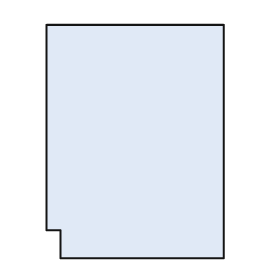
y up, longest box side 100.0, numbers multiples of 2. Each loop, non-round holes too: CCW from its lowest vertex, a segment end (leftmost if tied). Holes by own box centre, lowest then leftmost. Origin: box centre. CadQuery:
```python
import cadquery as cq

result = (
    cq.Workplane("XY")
    .moveTo(-32.0, -50.0)
    .lineTo(38.0, -50.0)
    .lineTo(38.0, 50.0)
    .lineTo(-38.0, 50.0)
    .lineTo(-38.0, -38.0)
    .lineTo(-32.0, -38.0)
    .close()
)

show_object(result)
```